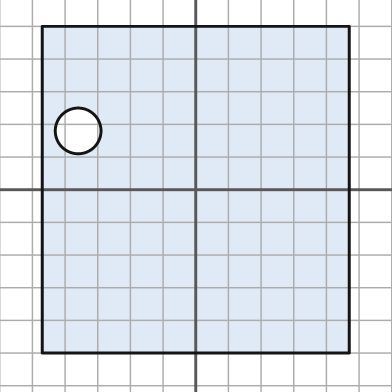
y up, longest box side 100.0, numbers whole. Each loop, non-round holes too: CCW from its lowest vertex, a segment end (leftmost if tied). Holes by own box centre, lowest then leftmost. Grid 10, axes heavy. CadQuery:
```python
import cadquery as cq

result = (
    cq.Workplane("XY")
    .moveTo(-47.0, -50.0)
    .lineTo(47.0, -50.0)
    .lineTo(47.0, 50.0)
    .lineTo(-47.0, 50.0)
    .close()
    .moveTo(-36.0, 18.0)
    .circle(7.0)
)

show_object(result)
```